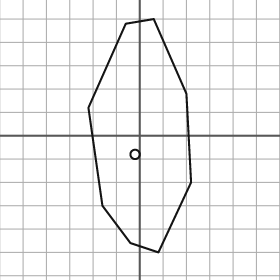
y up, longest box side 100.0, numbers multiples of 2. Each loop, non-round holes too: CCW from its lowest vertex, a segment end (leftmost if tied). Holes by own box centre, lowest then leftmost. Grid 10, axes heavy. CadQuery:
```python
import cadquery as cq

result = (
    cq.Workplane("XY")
    .moveTo(8.0, -50.0)
    .lineTo(22.0, -20.0)
    .lineTo(20.0, 18.0)
    .lineTo(6.0, 50.0)
    .lineTo(-6.0, 48.0)
    .lineTo(-22.0, 12.0)
    .lineTo(-16.0, -30.0)
    .lineTo(-4.0, -46.0)
    .close()
    .moveTo(-2.0, -8.0)
    .circle(2.0)
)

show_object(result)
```